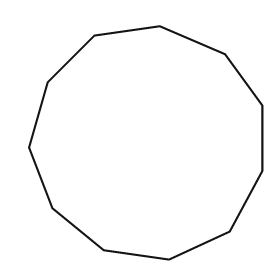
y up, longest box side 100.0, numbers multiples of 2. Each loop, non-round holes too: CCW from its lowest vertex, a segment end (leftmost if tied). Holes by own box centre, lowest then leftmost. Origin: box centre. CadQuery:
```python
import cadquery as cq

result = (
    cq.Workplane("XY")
    .moveTo(10.0, -50.0)
    .lineTo(36.0, -38.0)
    .lineTo(50.0, -12.0)
    .lineTo(50.0, 16.0)
    .lineTo(34.0, 38.0)
    .lineTo(6.0, 50.0)
    .lineTo(-22.0, 46.0)
    .lineTo(-42.0, 26.0)
    .lineTo(-50.0, -2.0)
    .lineTo(-40.0, -28.0)
    .lineTo(-18.0, -46.0)
    .close()
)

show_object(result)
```